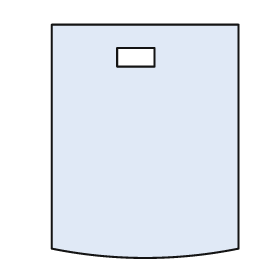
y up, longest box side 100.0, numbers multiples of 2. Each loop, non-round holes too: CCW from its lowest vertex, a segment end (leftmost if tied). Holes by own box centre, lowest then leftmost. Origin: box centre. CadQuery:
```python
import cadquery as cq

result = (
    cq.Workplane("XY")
    .moveTo(-40.0, -46.0)
    .threePointArc((0.0, -50.0), (40.0, -46.0))
    .lineTo(40.0, 50.0)
    .lineTo(-40.0, 50.0)
    .close()
    .moveTo(-12.0, 32.0)
    .lineTo(4.0, 32.0)
    .lineTo(4.0, 40.0)
    .lineTo(-12.0, 40.0)
    .close()
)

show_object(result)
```